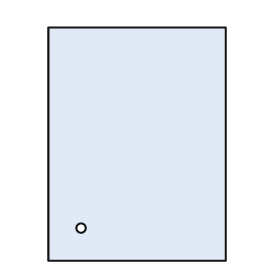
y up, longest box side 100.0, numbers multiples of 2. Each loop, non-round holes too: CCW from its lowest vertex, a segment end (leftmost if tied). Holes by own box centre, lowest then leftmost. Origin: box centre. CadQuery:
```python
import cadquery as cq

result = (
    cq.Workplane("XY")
    .moveTo(-38.0, -50.0)
    .lineTo(38.0, -50.0)
    .lineTo(38.0, 50.0)
    .lineTo(-38.0, 50.0)
    .close()
    .moveTo(-24.0, -36.0)
    .circle(2.0)
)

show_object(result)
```